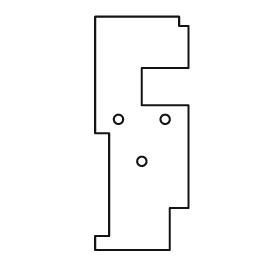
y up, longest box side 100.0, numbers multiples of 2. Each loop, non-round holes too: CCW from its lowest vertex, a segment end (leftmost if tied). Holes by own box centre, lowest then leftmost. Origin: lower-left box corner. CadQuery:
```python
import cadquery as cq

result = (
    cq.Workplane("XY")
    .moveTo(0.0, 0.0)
    .lineTo(32.0, 0.0)
    .lineTo(32.0, 18.0)
    .lineTo(40.0, 18.0)
    .lineTo(40.0, 62.0)
    .lineTo(20.0, 62.0)
    .lineTo(20.0, 78.0)
    .lineTo(40.0, 78.0)
    .lineTo(40.0, 96.0)
    .lineTo(36.0, 96.0)
    .lineTo(36.0, 100.0)
    .lineTo(0.0, 100.0)
    .lineTo(0.0, 50.0)
    .lineTo(6.0, 50.0)
    .lineTo(6.0, 6.0)
    .lineTo(0.0, 6.0)
    .close()
    .moveTo(20.0, 38.0)
    .circle(2.0)
    .moveTo(10.0, 56.0)
    .circle(2.0)
    .moveTo(30.0, 56.0)
    .circle(2.0)
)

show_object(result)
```